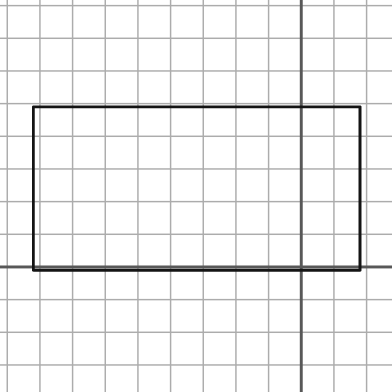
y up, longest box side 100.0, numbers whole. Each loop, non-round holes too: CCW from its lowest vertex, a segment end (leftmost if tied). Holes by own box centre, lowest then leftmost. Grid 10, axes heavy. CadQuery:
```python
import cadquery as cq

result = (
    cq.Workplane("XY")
    .moveTo(-82.0, -1.0)
    .lineTo(18.0, -1.0)
    .lineTo(18.0, 49.0)
    .lineTo(-82.0, 49.0)
    .close()
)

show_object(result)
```